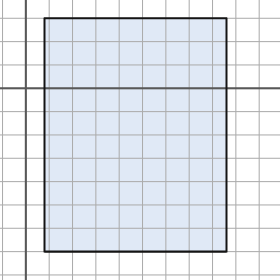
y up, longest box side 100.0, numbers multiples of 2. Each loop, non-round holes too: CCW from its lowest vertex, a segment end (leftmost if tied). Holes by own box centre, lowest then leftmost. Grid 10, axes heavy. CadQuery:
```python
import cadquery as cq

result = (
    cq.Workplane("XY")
    .moveTo(8.0, -70.0)
    .lineTo(86.0, -70.0)
    .lineTo(86.0, 30.0)
    .lineTo(8.0, 30.0)
    .close()
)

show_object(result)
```